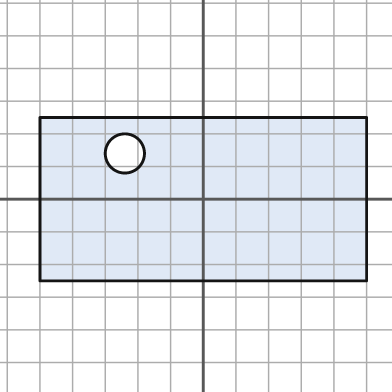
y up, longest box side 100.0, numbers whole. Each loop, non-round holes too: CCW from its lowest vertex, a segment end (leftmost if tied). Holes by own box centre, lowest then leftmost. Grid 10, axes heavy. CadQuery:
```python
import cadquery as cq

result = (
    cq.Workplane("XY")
    .moveTo(-50.0, -25.0)
    .lineTo(50.0, -25.0)
    .lineTo(50.0, 25.0)
    .lineTo(-50.0, 25.0)
    .close()
    .moveTo(-24.0, 14.0)
    .circle(6.0)
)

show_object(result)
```